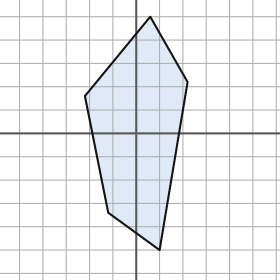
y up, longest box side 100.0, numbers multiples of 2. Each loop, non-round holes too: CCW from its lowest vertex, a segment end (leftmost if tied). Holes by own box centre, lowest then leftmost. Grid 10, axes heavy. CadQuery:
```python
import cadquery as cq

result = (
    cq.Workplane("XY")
    .moveTo(10.0, -50.0)
    .lineTo(22.0, 22.0)
    .lineTo(6.0, 50.0)
    .lineTo(-22.0, 16.0)
    .lineTo(-12.0, -34.0)
    .close()
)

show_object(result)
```